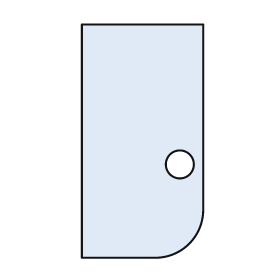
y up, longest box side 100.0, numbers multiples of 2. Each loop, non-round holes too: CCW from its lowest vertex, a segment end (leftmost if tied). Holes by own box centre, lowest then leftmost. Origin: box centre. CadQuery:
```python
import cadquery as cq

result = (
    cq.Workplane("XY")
    .moveTo(-26.0, -50.0)
    .lineTo(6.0, -50.0)
    .threePointArc((20.0, -44.0), (26.0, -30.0))
    .lineTo(26.0, 50.0)
    .lineTo(-26.0, 50.0)
    .close()
    .moveTo(16.0, -10.0)
    .circle(6.0)
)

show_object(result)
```